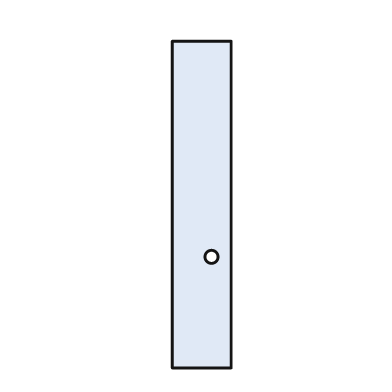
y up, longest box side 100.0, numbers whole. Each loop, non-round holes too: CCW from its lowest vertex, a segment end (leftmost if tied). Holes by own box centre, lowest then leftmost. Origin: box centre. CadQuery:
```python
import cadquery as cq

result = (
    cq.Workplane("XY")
    .moveTo(-9.0, -50.0)
    .lineTo(9.0, -50.0)
    .lineTo(9.0, 50.0)
    .lineTo(-9.0, 50.0)
    .close()
    .moveTo(3.0, -16.0)
    .circle(2.0)
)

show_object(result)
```